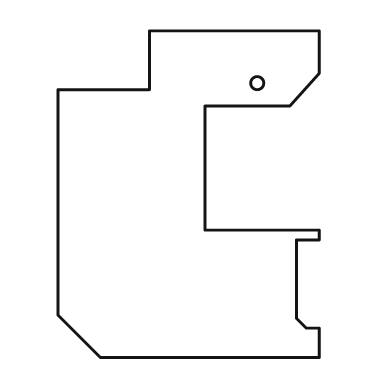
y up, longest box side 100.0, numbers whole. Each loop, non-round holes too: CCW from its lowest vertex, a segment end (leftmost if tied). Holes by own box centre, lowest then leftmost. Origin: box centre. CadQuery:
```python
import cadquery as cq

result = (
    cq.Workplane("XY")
    .moveTo(-27.0, -50.0)
    .lineTo(40.0, -50.0)
    .lineTo(40.0, -41.0)
    .lineTo(36.0, -41.0)
    .lineTo(33.0, -38.0)
    .lineTo(33.0, -14.0)
    .lineTo(40.0, -14.0)
    .lineTo(40.0, -11.0)
    .lineTo(5.0, -11.0)
    .lineTo(5.0, 27.0)
    .lineTo(31.0, 27.0)
    .lineTo(40.0, 37.0)
    .lineTo(40.0, 50.0)
    .lineTo(-12.0, 50.0)
    .lineTo(-12.0, 32.0)
    .lineTo(-40.0, 32.0)
    .lineTo(-40.0, -37.0)
    .close()
    .moveTo(21.0, 34.0)
    .circle(2.0)
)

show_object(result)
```